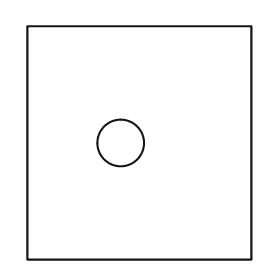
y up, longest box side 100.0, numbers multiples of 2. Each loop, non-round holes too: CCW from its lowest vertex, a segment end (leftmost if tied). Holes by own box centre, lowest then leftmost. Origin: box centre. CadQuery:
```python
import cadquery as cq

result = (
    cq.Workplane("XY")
    .moveTo(-48.0, -50.0)
    .lineTo(48.0, -50.0)
    .lineTo(48.0, 50.0)
    .lineTo(-48.0, 50.0)
    .close()
    .moveTo(-8.0, 0.0)
    .circle(10.0)
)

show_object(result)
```